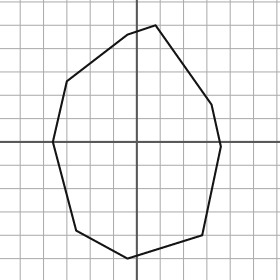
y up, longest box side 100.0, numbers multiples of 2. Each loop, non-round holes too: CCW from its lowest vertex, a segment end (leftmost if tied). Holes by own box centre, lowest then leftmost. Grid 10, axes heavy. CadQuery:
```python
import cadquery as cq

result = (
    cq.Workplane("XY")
    .moveTo(-4.0, -50.0)
    .lineTo(28.0, -40.0)
    .lineTo(36.0, -2.0)
    .lineTo(32.0, 16.0)
    .lineTo(8.0, 50.0)
    .lineTo(-4.0, 46.0)
    .lineTo(-30.0, 26.0)
    .lineTo(-36.0, 0.0)
    .lineTo(-26.0, -38.0)
    .close()
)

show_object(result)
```